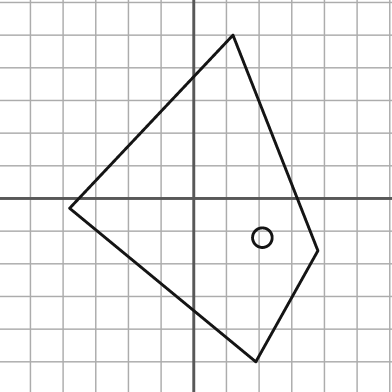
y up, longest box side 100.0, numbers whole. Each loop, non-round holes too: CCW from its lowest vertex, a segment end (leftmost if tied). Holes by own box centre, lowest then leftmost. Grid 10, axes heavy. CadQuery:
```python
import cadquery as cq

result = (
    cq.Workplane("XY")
    .moveTo(19.0, -50.0)
    .lineTo(38.0, -16.0)
    .lineTo(12.0, 50.0)
    .lineTo(-38.0, -3.0)
    .close()
    .moveTo(21.0, -12.0)
    .circle(3.0)
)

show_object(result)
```